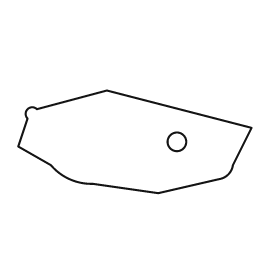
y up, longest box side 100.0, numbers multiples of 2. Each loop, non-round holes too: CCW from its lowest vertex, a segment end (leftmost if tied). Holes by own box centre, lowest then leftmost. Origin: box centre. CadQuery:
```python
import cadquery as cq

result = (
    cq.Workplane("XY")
    .moveTo(10.0, -22.0)
    .lineTo(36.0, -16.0)
    .threePointArc((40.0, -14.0), (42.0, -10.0))
    .lineTo(50.0, 6.0)
    .lineTo(-12.0, 22.0)
    .lineTo(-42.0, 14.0)
    .threePointArc((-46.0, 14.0), (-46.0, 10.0))
    .lineTo(-50.0, -2.0)
    .lineTo(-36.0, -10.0)
    .threePointArc((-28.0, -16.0), (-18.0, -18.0))
    .close()
    .moveTo(18.0, 0.0)
    .circle(4.0)
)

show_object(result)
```